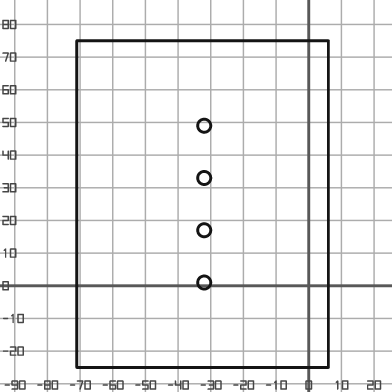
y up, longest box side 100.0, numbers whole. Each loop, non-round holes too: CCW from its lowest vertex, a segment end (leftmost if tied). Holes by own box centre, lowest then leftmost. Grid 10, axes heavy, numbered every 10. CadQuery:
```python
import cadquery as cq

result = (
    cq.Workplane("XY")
    .moveTo(-71.0, -25.0)
    .lineTo(6.0, -25.0)
    .lineTo(6.0, 75.0)
    .lineTo(-71.0, 75.0)
    .close()
    .moveTo(-32.0, 1.0)
    .circle(2.0)
    .moveTo(-32.0, 17.0)
    .circle(2.0)
    .moveTo(-32.0, 33.0)
    .circle(2.0)
    .moveTo(-32.0, 49.0)
    .circle(2.0)
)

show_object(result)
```